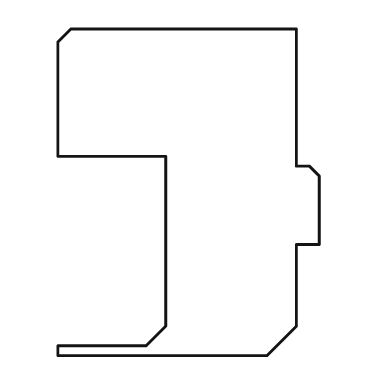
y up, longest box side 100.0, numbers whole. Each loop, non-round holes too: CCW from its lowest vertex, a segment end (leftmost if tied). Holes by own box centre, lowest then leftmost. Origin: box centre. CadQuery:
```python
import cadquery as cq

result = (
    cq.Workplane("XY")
    .moveTo(-40.0, -50.0)
    .lineTo(24.0, -50.0)
    .lineTo(33.0, -41.0)
    .lineTo(33.0, -16.0)
    .lineTo(40.0, -16.0)
    .lineTo(40.0, 5.0)
    .lineTo(37.0, 8.0)
    .lineTo(33.0, 8.0)
    .lineTo(33.0, 50.0)
    .lineTo(-36.0, 50.0)
    .lineTo(-40.0, 46.0)
    .lineTo(-40.0, 11.0)
    .lineTo(-7.0, 11.0)
    .lineTo(-7.0, -41.0)
    .lineTo(-13.0, -47.0)
    .lineTo(-40.0, -47.0)
    .close()
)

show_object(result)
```